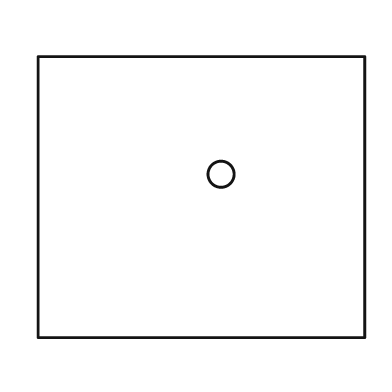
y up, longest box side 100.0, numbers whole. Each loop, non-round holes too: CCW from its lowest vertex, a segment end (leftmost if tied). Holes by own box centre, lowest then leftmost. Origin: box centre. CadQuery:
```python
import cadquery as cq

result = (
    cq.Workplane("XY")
    .moveTo(-50.0, -43.0)
    .lineTo(50.0, -43.0)
    .lineTo(50.0, 43.0)
    .lineTo(-50.0, 43.0)
    .close()
    .moveTo(6.0, 7.0)
    .circle(4.0)
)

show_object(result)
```